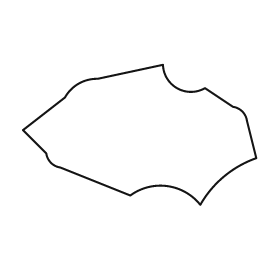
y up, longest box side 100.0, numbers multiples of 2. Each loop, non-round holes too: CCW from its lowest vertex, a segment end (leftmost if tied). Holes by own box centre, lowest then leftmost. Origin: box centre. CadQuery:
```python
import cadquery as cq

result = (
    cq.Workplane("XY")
    .moveTo(26.0, -30.0)
    .threePointArc((36.0, -18.0), (50.0, -10.0))
    .lineTo(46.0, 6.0)
    .threePointArc((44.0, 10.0), (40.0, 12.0))
    .lineTo(28.0, 20.0)
    .threePointArc((16.0, 20.0), (10.0, 30.0))
    .lineTo(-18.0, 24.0)
    .threePointArc((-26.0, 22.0), (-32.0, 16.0))
    .lineTo(-50.0, 2.0)
    .lineTo(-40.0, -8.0)
    .threePointArc((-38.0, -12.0), (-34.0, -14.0))
    .lineTo(-4.0, -26.0)
    .threePointArc((12.0, -22.0), (26.0, -30.0))
    .close()
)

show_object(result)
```